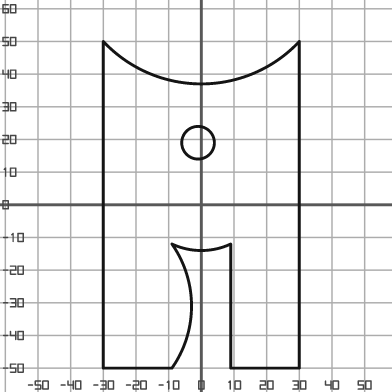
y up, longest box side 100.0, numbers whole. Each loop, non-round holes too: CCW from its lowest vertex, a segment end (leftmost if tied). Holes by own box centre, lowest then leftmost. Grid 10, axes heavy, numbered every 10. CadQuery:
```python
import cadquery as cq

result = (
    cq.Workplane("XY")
    .moveTo(-30.0, -50.0)
    .lineTo(-9.0, -50.0)
    .threePointArc((-3.0, -31.0), (-9.0, -12.0))
    .threePointArc((0.0, -14.0), (9.0, -12.0))
    .lineTo(9.0, -50.0)
    .lineTo(30.0, -50.0)
    .lineTo(30.0, 50.0)
    .threePointArc((0.0, 37.0), (-30.0, 50.0))
    .close()
    .moveTo(-1.0, 19.0)
    .circle(5.0)
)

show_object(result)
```